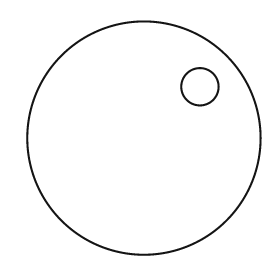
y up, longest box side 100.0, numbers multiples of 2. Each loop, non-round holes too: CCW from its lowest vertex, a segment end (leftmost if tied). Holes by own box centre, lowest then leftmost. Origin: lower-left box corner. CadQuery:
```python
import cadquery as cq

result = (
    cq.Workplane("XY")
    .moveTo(50.0, 50.0)
    .circle(50.0)
    .moveTo(74.0, 72.0)
    .circle(8.0)
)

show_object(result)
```